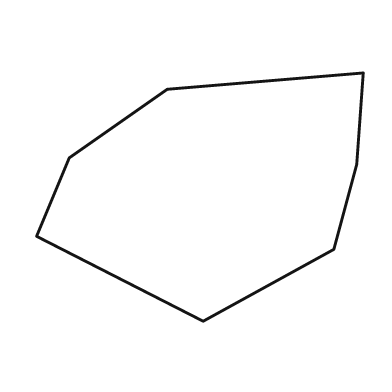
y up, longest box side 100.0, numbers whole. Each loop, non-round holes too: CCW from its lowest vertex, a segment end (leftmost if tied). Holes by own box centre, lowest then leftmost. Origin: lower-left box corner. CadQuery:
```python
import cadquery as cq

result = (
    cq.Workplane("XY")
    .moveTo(51.0, 0.0)
    .lineTo(91.0, 22.0)
    .lineTo(98.0, 48.0)
    .lineTo(100.0, 76.0)
    .lineTo(40.0, 71.0)
    .lineTo(10.0, 50.0)
    .lineTo(0.0, 26.0)
    .close()
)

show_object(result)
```